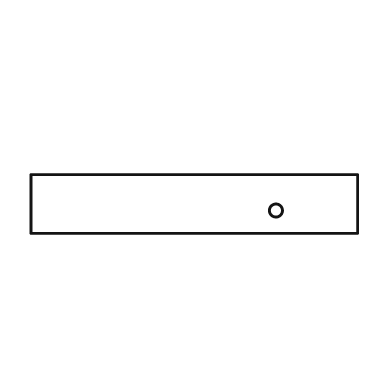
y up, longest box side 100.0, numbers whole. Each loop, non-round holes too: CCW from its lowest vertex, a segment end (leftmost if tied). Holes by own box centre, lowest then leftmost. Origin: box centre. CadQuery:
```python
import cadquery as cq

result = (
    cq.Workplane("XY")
    .moveTo(-50.0, -9.0)
    .lineTo(50.0, -9.0)
    .lineTo(50.0, 9.0)
    .lineTo(-50.0, 9.0)
    .close()
    .moveTo(25.0, -2.0)
    .circle(2.0)
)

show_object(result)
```